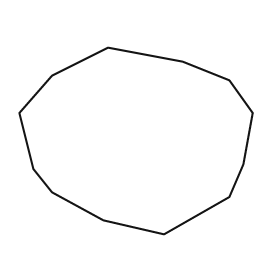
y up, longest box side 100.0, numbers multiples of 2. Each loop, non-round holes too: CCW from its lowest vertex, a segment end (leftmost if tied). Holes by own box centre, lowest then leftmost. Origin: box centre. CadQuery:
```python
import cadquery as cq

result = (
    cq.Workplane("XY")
    .moveTo(12.0, -40.0)
    .lineTo(40.0, -24.0)
    .lineTo(46.0, -10.0)
    .lineTo(50.0, 12.0)
    .lineTo(40.0, 26.0)
    .lineTo(20.0, 34.0)
    .lineTo(-12.0, 40.0)
    .lineTo(-36.0, 28.0)
    .lineTo(-50.0, 12.0)
    .lineTo(-44.0, -12.0)
    .lineTo(-36.0, -22.0)
    .lineTo(-14.0, -34.0)
    .close()
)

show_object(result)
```